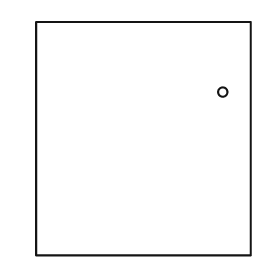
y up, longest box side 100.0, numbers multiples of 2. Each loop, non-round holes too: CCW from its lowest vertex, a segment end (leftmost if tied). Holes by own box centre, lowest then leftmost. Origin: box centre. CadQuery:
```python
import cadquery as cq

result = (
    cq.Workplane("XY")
    .moveTo(-46.0, -50.0)
    .lineTo(46.0, -50.0)
    .lineTo(46.0, 50.0)
    .lineTo(-46.0, 50.0)
    .close()
    .moveTo(34.0, 20.0)
    .circle(2.0)
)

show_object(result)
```